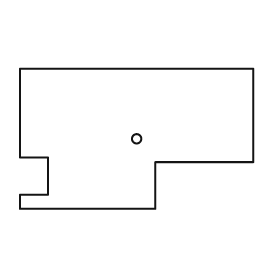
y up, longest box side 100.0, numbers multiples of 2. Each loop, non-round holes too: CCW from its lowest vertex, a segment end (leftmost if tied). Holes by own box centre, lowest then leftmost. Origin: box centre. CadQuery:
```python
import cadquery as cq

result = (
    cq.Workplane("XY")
    .moveTo(-50.0, -30.0)
    .lineTo(8.0, -30.0)
    .lineTo(8.0, -10.0)
    .lineTo(50.0, -10.0)
    .lineTo(50.0, 30.0)
    .lineTo(-50.0, 30.0)
    .lineTo(-50.0, -8.0)
    .lineTo(-38.0, -8.0)
    .lineTo(-38.0, -24.0)
    .lineTo(-50.0, -24.0)
    .close()
    .moveTo(0.0, 0.0)
    .circle(2.0)
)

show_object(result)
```